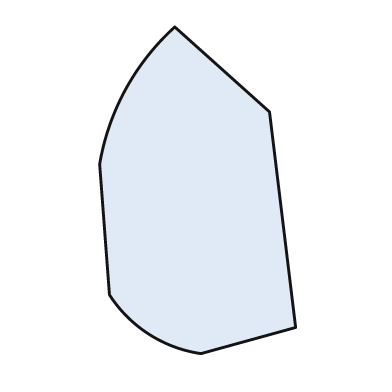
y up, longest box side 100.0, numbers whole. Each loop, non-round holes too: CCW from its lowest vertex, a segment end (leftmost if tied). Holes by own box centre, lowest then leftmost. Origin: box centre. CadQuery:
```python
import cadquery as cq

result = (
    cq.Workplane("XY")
    .moveTo(1.0, -50.0)
    .lineTo(30.0, -42.0)
    .lineTo(22.0, 24.0)
    .lineTo(-7.0, 50.0)
    .threePointArc((-22.0, 31.0), (-30.0, 8.0))
    .lineTo(-27.0, -32.0)
    .threePointArc((-15.0, -44.0), (1.0, -50.0))
    .close()
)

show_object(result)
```